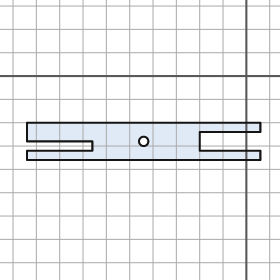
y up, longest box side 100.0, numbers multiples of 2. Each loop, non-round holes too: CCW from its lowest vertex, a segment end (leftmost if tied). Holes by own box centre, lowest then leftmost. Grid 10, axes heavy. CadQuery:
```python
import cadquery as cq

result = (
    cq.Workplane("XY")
    .moveTo(-94.0, -36.0)
    .lineTo(6.0, -36.0)
    .lineTo(6.0, -32.0)
    .lineTo(-20.0, -32.0)
    .lineTo(-20.0, -24.0)
    .lineTo(6.0, -24.0)
    .lineTo(6.0, -20.0)
    .lineTo(-94.0, -20.0)
    .lineTo(-94.0, -28.0)
    .lineTo(-66.0, -28.0)
    .lineTo(-66.0, -32.0)
    .lineTo(-94.0, -32.0)
    .close()
    .moveTo(-44.0, -28.0)
    .circle(2.0)
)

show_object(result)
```